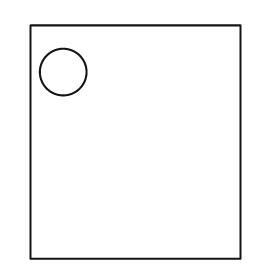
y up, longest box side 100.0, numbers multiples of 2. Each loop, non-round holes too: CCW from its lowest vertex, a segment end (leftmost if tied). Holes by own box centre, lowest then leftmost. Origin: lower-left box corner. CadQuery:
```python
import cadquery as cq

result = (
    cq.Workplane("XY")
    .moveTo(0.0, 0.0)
    .lineTo(90.0, 0.0)
    .lineTo(90.0, 100.0)
    .lineTo(0.0, 100.0)
    .close()
    .moveTo(14.0, 80.0)
    .circle(10.0)
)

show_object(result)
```